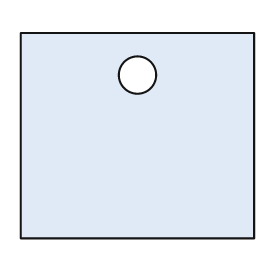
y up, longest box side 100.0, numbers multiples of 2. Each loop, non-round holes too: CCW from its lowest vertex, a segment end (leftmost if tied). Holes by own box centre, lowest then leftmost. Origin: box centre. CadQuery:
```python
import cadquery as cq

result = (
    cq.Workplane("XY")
    .moveTo(-50.0, -44.0)
    .lineTo(50.0, -44.0)
    .lineTo(50.0, 44.0)
    .lineTo(-50.0, 44.0)
    .close()
    .moveTo(0.0, 26.0)
    .circle(8.0)
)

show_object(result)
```